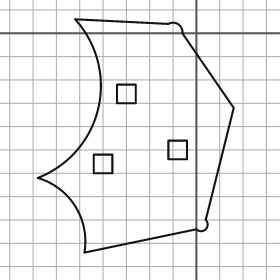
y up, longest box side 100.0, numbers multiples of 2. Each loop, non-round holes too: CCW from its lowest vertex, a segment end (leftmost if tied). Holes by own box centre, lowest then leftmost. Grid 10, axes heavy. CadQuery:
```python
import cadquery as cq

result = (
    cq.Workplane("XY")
    .moveTo(-48.0, -94.0)
    .lineTo(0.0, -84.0)
    .threePointArc((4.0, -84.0), (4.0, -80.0))
    .lineTo(16.0, -32.0)
    .lineTo(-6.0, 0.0)
    .threePointArc((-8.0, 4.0), (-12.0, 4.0))
    .lineTo(-52.0, 6.0)
    .threePointArc((-42.0, -32.0), (-68.0, -62.0))
    .threePointArc((-52.0, -74.0), (-48.0, -94.0))
    .close()
    .moveTo(-44.0, -60.0)
    .lineTo(-36.0, -60.0)
    .lineTo(-36.0, -52.0)
    .lineTo(-44.0, -52.0)
    .close()
    .moveTo(-12.0, -54.0)
    .lineTo(-4.0, -54.0)
    .lineTo(-4.0, -46.0)
    .lineTo(-12.0, -46.0)
    .close()
    .moveTo(-34.0, -30.0)
    .lineTo(-26.0, -30.0)
    .lineTo(-26.0, -22.0)
    .lineTo(-34.0, -22.0)
    .close()
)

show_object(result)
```